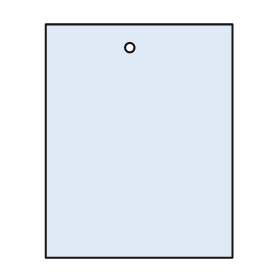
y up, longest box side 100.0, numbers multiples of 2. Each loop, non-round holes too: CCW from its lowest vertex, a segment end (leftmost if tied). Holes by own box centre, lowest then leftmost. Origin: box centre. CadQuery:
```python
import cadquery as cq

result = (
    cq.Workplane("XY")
    .moveTo(-40.0, -50.0)
    .lineTo(40.0, -50.0)
    .lineTo(40.0, 50.0)
    .lineTo(-40.0, 50.0)
    .close()
    .moveTo(-4.0, 40.0)
    .circle(2.0)
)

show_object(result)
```